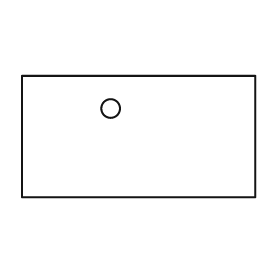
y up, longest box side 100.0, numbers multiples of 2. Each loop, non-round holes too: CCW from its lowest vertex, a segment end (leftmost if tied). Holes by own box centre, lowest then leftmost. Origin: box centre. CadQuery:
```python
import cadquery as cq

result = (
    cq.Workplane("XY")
    .moveTo(-50.0, -26.0)
    .lineTo(50.0, -26.0)
    .lineTo(50.0, 26.0)
    .lineTo(-50.0, 26.0)
    .close()
    .moveTo(-12.0, 12.0)
    .circle(4.0)
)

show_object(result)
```